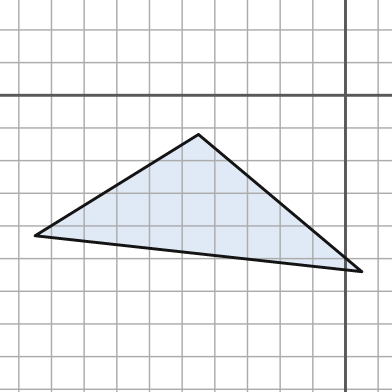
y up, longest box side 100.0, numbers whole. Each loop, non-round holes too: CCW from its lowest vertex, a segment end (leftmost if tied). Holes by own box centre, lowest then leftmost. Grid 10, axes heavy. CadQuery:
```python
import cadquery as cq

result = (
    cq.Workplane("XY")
    .moveTo(5.0, -54.0)
    .lineTo(-45.0, -12.0)
    .lineTo(-95.0, -43.0)
    .close()
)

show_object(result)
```